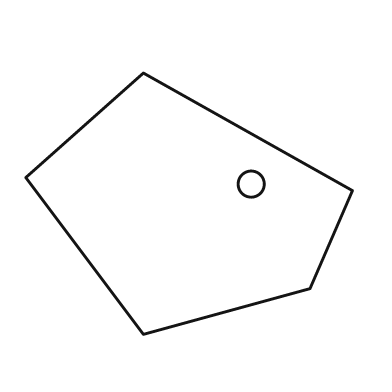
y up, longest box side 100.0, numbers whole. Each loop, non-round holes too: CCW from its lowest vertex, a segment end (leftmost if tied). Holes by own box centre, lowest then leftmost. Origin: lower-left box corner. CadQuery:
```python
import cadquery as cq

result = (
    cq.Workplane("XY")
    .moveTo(36.0, 0.0)
    .lineTo(87.0, 14.0)
    .lineTo(100.0, 44.0)
    .lineTo(36.0, 80.0)
    .lineTo(0.0, 48.0)
    .close()
    .moveTo(69.0, 46.0)
    .circle(4.0)
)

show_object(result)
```